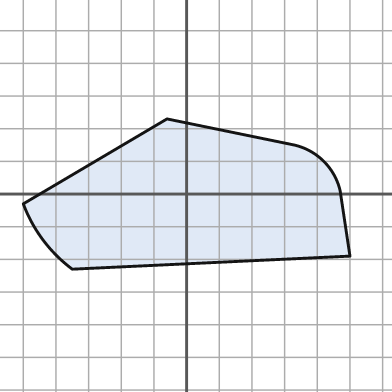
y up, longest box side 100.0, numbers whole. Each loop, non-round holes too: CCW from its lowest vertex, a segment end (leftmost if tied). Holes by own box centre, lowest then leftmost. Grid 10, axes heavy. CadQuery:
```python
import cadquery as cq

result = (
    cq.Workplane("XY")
    .moveTo(-35.0, -23.0)
    .lineTo(50.0, -19.0)
    .lineTo(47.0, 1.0)
    .threePointArc((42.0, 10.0), (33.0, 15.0))
    .lineTo(-6.0, 23.0)
    .lineTo(-50.0, -3.0)
    .threePointArc((-44.0, -14.0), (-35.0, -23.0))
    .close()
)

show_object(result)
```